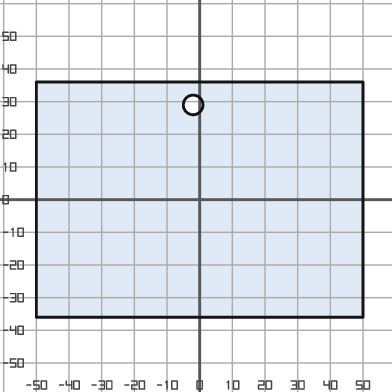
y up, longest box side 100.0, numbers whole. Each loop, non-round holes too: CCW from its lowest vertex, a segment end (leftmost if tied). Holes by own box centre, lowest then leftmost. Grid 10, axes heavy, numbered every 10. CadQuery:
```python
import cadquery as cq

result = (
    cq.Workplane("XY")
    .moveTo(-50.0, -36.0)
    .lineTo(50.0, -36.0)
    .lineTo(50.0, 36.0)
    .lineTo(-50.0, 36.0)
    .close()
    .moveTo(-2.0, 29.0)
    .circle(3.0)
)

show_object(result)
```